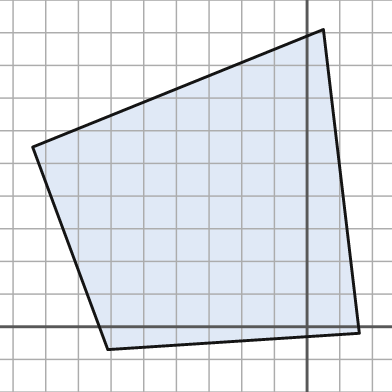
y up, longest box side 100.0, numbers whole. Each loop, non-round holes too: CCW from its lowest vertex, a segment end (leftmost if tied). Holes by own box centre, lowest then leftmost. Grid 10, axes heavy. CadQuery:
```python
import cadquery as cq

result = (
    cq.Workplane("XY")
    .moveTo(-61.0, -7.0)
    .lineTo(16.0, -2.0)
    .lineTo(5.0, 91.0)
    .lineTo(-84.0, 55.0)
    .close()
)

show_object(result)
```